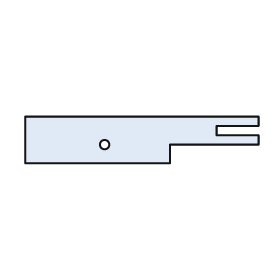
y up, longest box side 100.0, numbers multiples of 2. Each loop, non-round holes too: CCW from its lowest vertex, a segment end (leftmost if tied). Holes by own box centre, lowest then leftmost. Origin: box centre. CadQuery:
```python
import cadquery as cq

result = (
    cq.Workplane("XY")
    .moveTo(-50.0, -10.0)
    .lineTo(12.0, -10.0)
    .lineTo(12.0, -2.0)
    .lineTo(50.0, -2.0)
    .lineTo(50.0, 2.0)
    .lineTo(32.0, 2.0)
    .lineTo(32.0, 6.0)
    .lineTo(50.0, 6.0)
    .lineTo(50.0, 10.0)
    .lineTo(-50.0, 10.0)
    .close()
    .moveTo(-16.0, -2.0)
    .circle(2.0)
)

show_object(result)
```